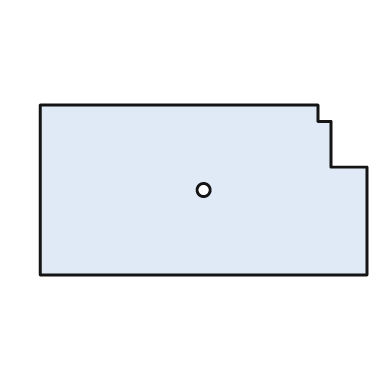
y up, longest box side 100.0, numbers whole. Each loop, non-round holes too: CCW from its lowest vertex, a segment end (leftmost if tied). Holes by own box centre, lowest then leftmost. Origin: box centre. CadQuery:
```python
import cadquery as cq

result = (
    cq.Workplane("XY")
    .moveTo(-50.0, -26.0)
    .lineTo(50.0, -26.0)
    .lineTo(50.0, 7.0)
    .lineTo(39.0, 7.0)
    .lineTo(39.0, 21.0)
    .lineTo(35.0, 21.0)
    .lineTo(35.0, 26.0)
    .lineTo(-50.0, 26.0)
    .close()
    .moveTo(0.0, 0.0)
    .circle(2.0)
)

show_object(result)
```